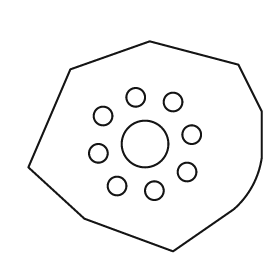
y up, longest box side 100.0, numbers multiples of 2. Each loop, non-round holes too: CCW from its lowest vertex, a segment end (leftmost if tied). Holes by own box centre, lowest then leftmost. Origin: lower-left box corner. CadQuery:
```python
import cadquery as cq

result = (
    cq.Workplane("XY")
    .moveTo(62.0, 0.0)
    .lineTo(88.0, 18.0)
    .threePointArc((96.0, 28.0), (100.0, 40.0))
    .lineTo(100.0, 60.0)
    .lineTo(90.0, 80.0)
    .lineTo(52.0, 90.0)
    .lineTo(18.0, 78.0)
    .lineTo(0.0, 36.0)
    .lineTo(24.0, 14.0)
    .close()
    .moveTo(54.0, 26.0)
    .circle(4.0)
    .moveTo(38.0, 28.0)
    .circle(4.0)
    .moveTo(68.0, 34.0)
    .circle(4.0)
    .moveTo(30.0, 42.0)
    .circle(4.0)
    .moveTo(50.0, 46.0)
    .circle(10.0)
    .moveTo(70.0, 50.0)
    .circle(4.0)
    .moveTo(32.0, 58.0)
    .circle(4.0)
    .moveTo(62.0, 64.0)
    .circle(4.0)
    .moveTo(46.0, 66.0)
    .circle(4.0)
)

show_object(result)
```